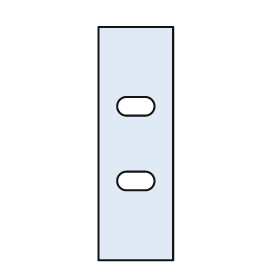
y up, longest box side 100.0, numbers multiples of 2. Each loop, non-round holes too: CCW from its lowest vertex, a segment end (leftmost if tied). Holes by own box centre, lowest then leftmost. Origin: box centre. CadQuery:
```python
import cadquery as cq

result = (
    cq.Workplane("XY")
    .moveTo(-16.0, -50.0)
    .lineTo(16.0, -50.0)
    .lineTo(16.0, 50.0)
    .lineTo(-16.0, 50.0)
    .close()
    .moveTo(-4.0, -20.0)
    .lineTo(4.0, -20.0)
    .threePointArc((8.0, -16.0), (4.0, -12.0))
    .lineTo(-4.0, -12.0)
    .threePointArc((-8.0, -16.0), (-4.0, -20.0))
    .close()
    .moveTo(-4.0, 12.0)
    .lineTo(4.0, 12.0)
    .threePointArc((8.0, 16.0), (4.0, 20.0))
    .lineTo(-4.0, 20.0)
    .threePointArc((-8.0, 16.0), (-4.0, 12.0))
    .close()
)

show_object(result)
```